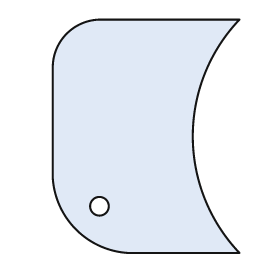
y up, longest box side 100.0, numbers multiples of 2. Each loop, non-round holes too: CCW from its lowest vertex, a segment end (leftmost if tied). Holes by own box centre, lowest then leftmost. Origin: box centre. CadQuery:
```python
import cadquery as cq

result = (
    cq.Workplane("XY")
    .moveTo(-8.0, -50.0)
    .lineTo(40.0, -50.0)
    .threePointArc((20.0, 0.0), (40.0, 50.0))
    .lineTo(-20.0, 50.0)
    .threePointArc((-34.0, 44.0), (-40.0, 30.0))
    .lineTo(-40.0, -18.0)
    .threePointArc((-30.0, -40.0), (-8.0, -50.0))
    .close()
    .moveTo(-20.0, -30.0)
    .circle(4.0)
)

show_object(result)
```